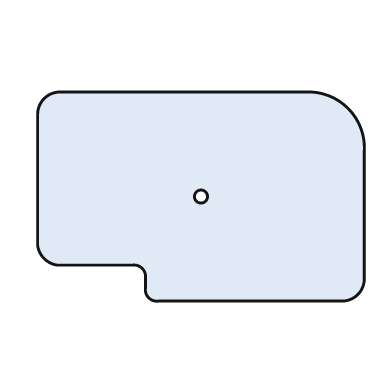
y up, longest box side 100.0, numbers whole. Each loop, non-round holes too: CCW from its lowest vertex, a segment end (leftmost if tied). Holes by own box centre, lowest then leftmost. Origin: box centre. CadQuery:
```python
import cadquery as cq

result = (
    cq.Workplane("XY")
    .moveTo(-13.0, -32.0)
    .lineTo(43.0, -32.0)
    .threePointArc((48.0, -30.0), (50.0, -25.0))
    .lineTo(50.0, 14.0)
    .threePointArc((45.0, 27.0), (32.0, 32.0))
    .lineTo(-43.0, 32.0)
    .threePointArc((-48.0, 30.0), (-50.0, 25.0))
    .lineTo(-50.0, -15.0)
    .threePointArc((-48.0, -19.0), (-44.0, -21.0))
    .lineTo(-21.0, -21.0)
    .threePointArc((-18.0, -22.0), (-17.0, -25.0))
    .lineTo(-17.0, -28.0)
    .threePointArc((-16.0, -31.0), (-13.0, -32.0))
    .close()
    .moveTo(0.0, 0.0)
    .circle(2.0)
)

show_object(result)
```